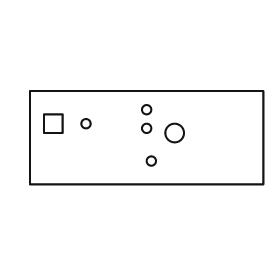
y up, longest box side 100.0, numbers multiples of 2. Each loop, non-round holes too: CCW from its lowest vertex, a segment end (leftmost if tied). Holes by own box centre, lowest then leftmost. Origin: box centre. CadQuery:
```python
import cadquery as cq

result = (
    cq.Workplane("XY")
    .moveTo(-50.0, -20.0)
    .lineTo(50.0, -20.0)
    .lineTo(50.0, 20.0)
    .lineTo(-50.0, 20.0)
    .close()
    .moveTo(2.0, -10.0)
    .circle(2.0)
    .moveTo(12.0, 2.0)
    .circle(4.0)
    .moveTo(0.0, 4.0)
    .circle(2.0)
    .moveTo(-44.0, 2.0)
    .lineTo(-36.0, 2.0)
    .lineTo(-36.0, 10.0)
    .lineTo(-44.0, 10.0)
    .close()
    .moveTo(-26.0, 6.0)
    .circle(2.0)
    .moveTo(0.0, 12.0)
    .circle(2.0)
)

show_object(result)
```